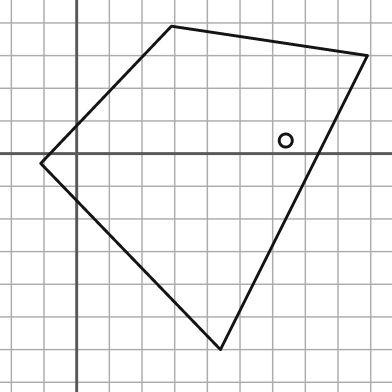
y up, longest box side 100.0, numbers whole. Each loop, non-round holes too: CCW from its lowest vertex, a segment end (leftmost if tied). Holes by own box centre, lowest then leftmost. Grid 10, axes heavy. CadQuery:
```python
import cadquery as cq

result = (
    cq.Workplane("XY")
    .moveTo(44.0, -60.0)
    .lineTo(89.0, 30.0)
    .lineTo(29.0, 39.0)
    .lineTo(-11.0, -3.0)
    .close()
    .moveTo(64.0, 4.0)
    .circle(2.0)
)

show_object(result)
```